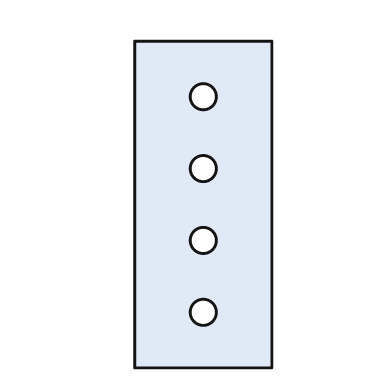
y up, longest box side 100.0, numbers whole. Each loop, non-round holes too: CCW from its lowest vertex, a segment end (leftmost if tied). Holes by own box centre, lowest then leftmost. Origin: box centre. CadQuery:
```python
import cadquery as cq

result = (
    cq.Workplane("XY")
    .moveTo(-21.0, -50.0)
    .lineTo(21.0, -50.0)
    .lineTo(21.0, 50.0)
    .lineTo(-21.0, 50.0)
    .close()
    .moveTo(0.0, -33.0)
    .circle(4.0)
    .moveTo(0.0, -11.0)
    .circle(4.0)
    .moveTo(0.0, 11.0)
    .circle(4.0)
    .moveTo(0.0, 33.0)
    .circle(4.0)
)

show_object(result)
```